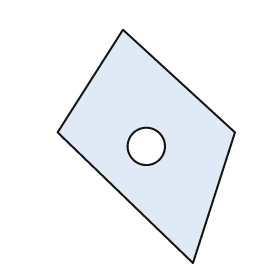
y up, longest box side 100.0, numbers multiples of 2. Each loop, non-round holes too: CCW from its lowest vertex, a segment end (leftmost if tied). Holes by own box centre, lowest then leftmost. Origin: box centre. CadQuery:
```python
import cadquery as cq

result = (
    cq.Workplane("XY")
    .moveTo(20.0, -50.0)
    .lineTo(38.0, 6.0)
    .lineTo(-10.0, 50.0)
    .lineTo(-38.0, 6.0)
    .close()
    .moveTo(0.0, 0.0)
    .circle(8.0)
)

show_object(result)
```